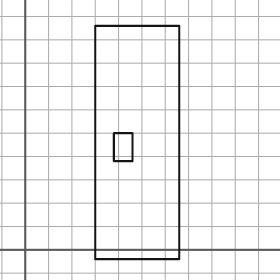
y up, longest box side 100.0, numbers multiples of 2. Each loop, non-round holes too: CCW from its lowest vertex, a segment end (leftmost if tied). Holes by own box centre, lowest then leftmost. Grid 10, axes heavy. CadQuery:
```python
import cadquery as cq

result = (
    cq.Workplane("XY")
    .moveTo(30.0, -4.0)
    .lineTo(66.0, -4.0)
    .lineTo(66.0, 96.0)
    .lineTo(30.0, 96.0)
    .close()
    .moveTo(38.0, 38.0)
    .lineTo(46.0, 38.0)
    .lineTo(46.0, 50.0)
    .lineTo(38.0, 50.0)
    .close()
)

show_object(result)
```